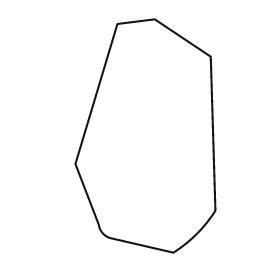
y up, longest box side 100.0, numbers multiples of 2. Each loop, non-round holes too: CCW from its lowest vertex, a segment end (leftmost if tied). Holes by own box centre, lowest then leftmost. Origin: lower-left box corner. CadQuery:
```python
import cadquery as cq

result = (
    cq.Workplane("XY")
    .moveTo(42.0, 0.0)
    .threePointArc((52.0, 8.0), (60.0, 18.0))
    .lineTo(58.0, 84.0)
    .lineTo(34.0, 100.0)
    .lineTo(18.0, 98.0)
    .lineTo(0.0, 38.0)
    .lineTo(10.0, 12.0)
    .threePointArc((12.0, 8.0), (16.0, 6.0))
    .close()
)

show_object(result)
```